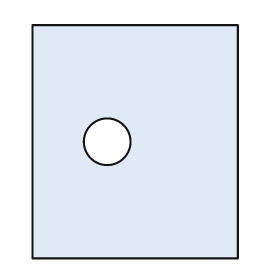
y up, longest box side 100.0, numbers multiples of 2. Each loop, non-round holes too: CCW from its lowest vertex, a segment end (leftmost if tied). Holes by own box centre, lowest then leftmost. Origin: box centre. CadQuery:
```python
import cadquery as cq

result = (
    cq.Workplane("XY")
    .moveTo(-44.0, -50.0)
    .lineTo(44.0, -50.0)
    .lineTo(44.0, 50.0)
    .lineTo(-44.0, 50.0)
    .close()
    .moveTo(-12.0, 0.0)
    .circle(10.0)
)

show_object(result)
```